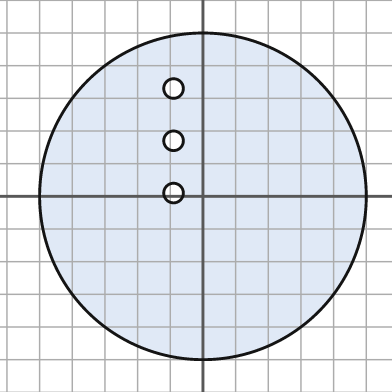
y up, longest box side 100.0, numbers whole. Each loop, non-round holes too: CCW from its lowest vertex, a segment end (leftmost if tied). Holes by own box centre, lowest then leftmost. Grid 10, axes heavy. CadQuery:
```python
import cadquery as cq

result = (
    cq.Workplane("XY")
    .moveTo(0.0, 0.0)
    .circle(50.0)
    .moveTo(-9.0, 1.0)
    .circle(3.0)
    .moveTo(-9.0, 17.0)
    .circle(3.0)
    .moveTo(-9.0, 33.0)
    .circle(3.0)
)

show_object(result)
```